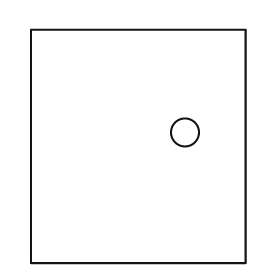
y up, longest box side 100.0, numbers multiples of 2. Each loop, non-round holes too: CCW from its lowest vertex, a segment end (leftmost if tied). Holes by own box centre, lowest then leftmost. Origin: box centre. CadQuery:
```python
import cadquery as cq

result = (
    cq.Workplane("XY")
    .moveTo(-46.0, -50.0)
    .lineTo(46.0, -50.0)
    .lineTo(46.0, 50.0)
    .lineTo(-46.0, 50.0)
    .close()
    .moveTo(20.0, 6.0)
    .circle(6.0)
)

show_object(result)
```